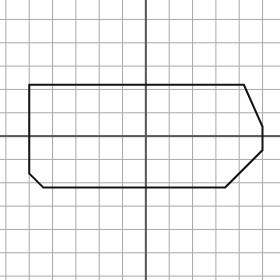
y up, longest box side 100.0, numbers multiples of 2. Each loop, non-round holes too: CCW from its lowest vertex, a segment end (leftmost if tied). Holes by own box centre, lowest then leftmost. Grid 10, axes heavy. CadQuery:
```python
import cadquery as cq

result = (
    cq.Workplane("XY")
    .moveTo(-44.0, -22.0)
    .lineTo(34.0, -22.0)
    .lineTo(50.0, -6.0)
    .lineTo(50.0, 4.0)
    .lineTo(42.0, 22.0)
    .lineTo(-50.0, 22.0)
    .lineTo(-50.0, -16.0)
    .close()
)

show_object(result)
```